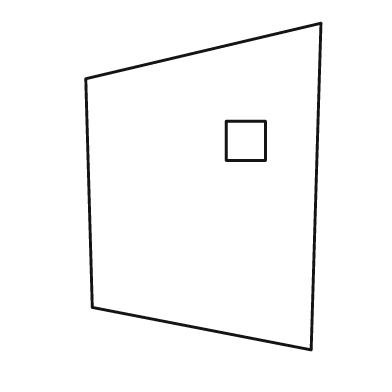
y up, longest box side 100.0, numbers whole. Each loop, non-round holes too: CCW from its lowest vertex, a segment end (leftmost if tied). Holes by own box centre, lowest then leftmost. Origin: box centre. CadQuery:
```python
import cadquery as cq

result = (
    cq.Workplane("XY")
    .moveTo(33.0, -50.0)
    .lineTo(36.0, 50.0)
    .lineTo(-36.0, 33.0)
    .lineTo(-34.0, -37.0)
    .close()
    .moveTo(7.0, 8.0)
    .lineTo(19.0, 8.0)
    .lineTo(19.0, 20.0)
    .lineTo(7.0, 20.0)
    .close()
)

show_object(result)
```